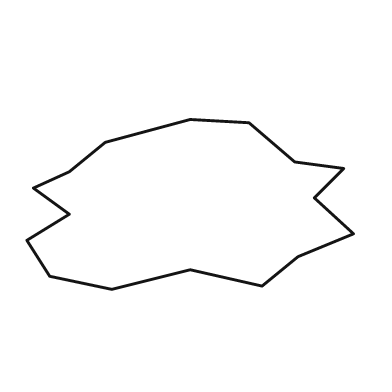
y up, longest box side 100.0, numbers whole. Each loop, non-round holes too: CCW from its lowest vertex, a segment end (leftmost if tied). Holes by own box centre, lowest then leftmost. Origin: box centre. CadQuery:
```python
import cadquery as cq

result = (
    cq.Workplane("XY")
    .moveTo(-24.0, -26.0)
    .lineTo(0.0, -20.0)
    .lineTo(22.0, -25.0)
    .lineTo(33.0, -16.0)
    .lineTo(50.0, -9.0)
    .lineTo(38.0, 2.0)
    .lineTo(47.0, 11.0)
    .lineTo(32.0, 13.0)
    .lineTo(18.0, 25.0)
    .lineTo(0.0, 26.0)
    .lineTo(-26.0, 19.0)
    .lineTo(-37.0, 10.0)
    .lineTo(-48.0, 5.0)
    .lineTo(-37.0, -3.0)
    .lineTo(-50.0, -11.0)
    .lineTo(-43.0, -22.0)
    .close()
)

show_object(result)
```